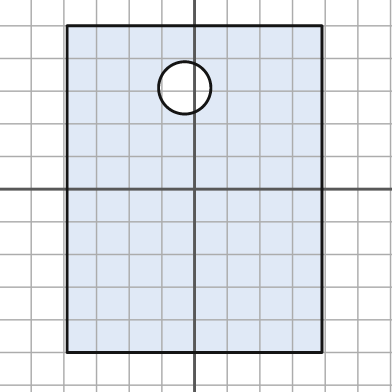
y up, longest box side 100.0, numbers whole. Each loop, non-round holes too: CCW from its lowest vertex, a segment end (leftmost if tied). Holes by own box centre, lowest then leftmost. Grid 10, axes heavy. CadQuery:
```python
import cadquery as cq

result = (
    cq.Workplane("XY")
    .moveTo(-39.0, -50.0)
    .lineTo(39.0, -50.0)
    .lineTo(39.0, 50.0)
    .lineTo(-39.0, 50.0)
    .close()
    .moveTo(-3.0, 31.0)
    .circle(8.0)
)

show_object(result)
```